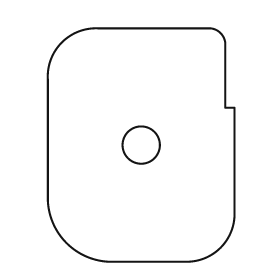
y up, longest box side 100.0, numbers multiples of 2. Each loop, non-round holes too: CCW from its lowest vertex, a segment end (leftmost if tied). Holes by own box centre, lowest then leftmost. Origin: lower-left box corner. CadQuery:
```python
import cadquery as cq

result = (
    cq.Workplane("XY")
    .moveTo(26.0, 0.0)
    .lineTo(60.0, 0.0)
    .threePointArc((74.0, 6.0), (80.0, 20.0))
    .lineTo(80.0, 66.0)
    .lineTo(76.0, 66.0)
    .lineTo(76.0, 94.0)
    .threePointArc((74.0, 98.0), (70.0, 100.0))
    .lineTo(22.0, 100.0)
    .threePointArc((6.0, 94.0), (0.0, 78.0))
    .lineTo(0.0, 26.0)
    .threePointArc((8.0, 8.0), (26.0, 0.0))
    .close()
    .moveTo(40.0, 50.0)
    .circle(8.0)
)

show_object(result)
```